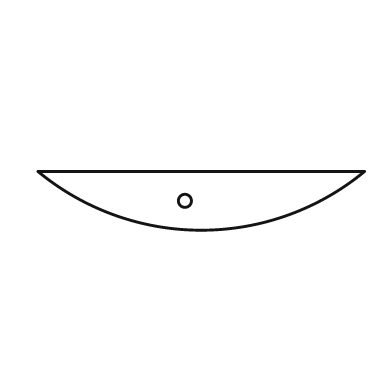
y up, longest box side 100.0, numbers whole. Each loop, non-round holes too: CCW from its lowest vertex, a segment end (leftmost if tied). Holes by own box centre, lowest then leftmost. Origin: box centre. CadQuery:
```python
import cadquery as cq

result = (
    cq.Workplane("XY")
    .moveTo(-50.0, 9.0)
    .threePointArc((0.0, -9.0), (50.0, 9.0))
    .close()
    .moveTo(-5.0, 0.0)
    .circle(2.0)
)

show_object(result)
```